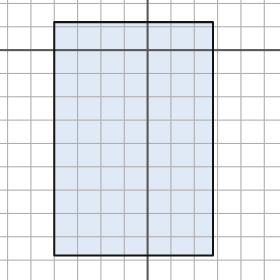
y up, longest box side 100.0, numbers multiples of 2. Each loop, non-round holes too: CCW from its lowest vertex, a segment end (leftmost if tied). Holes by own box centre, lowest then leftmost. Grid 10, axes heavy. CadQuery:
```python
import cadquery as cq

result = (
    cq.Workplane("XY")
    .moveTo(-40.0, -88.0)
    .lineTo(28.0, -88.0)
    .lineTo(28.0, 12.0)
    .lineTo(-40.0, 12.0)
    .close()
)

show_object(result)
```